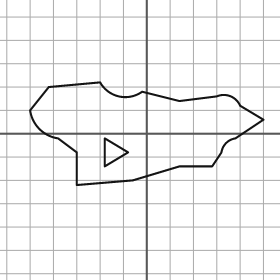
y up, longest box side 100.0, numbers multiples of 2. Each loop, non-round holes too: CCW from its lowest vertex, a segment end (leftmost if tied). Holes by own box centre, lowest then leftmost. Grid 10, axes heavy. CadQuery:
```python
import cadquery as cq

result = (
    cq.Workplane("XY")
    .moveTo(-30.0, -22.0)
    .lineTo(-6.0, -20.0)
    .lineTo(14.0, -14.0)
    .lineTo(28.0, -14.0)
    .lineTo(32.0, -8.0)
    .threePointArc((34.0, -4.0), (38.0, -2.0))
    .lineTo(50.0, 6.0)
    .lineTo(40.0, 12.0)
    .threePointArc((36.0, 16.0), (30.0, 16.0))
    .lineTo(14.0, 14.0)
    .lineTo(-2.0, 18.0)
    .threePointArc((-12.0, 16.0), (-20.0, 22.0))
    .lineTo(-42.0, 20.0)
    .lineTo(-50.0, 10.0)
    .threePointArc((-46.0, 2.0), (-38.0, -2.0))
    .lineTo(-30.0, -8.0)
    .close()
    .moveTo(-18.0, -14.0)
    .lineTo(-8.0, -8.0)
    .lineTo(-18.0, -2.0)
    .close()
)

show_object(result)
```